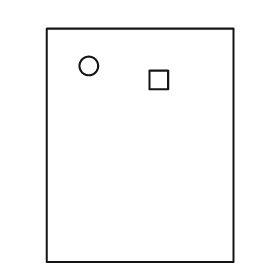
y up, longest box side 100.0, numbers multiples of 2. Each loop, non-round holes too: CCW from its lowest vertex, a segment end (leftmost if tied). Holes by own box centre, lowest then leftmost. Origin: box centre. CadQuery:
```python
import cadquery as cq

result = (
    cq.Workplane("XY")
    .moveTo(-40.0, -50.0)
    .lineTo(40.0, -50.0)
    .lineTo(40.0, 50.0)
    .lineTo(-40.0, 50.0)
    .close()
    .moveTo(4.0, 24.0)
    .lineTo(12.0, 24.0)
    .lineTo(12.0, 32.0)
    .lineTo(4.0, 32.0)
    .close()
    .moveTo(-22.0, 34.0)
    .circle(4.0)
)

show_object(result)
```